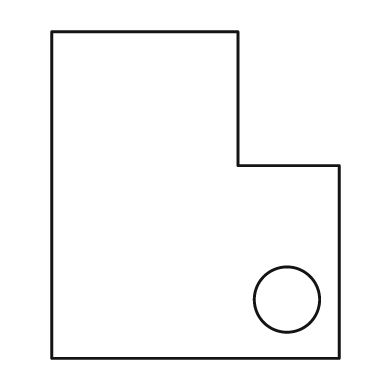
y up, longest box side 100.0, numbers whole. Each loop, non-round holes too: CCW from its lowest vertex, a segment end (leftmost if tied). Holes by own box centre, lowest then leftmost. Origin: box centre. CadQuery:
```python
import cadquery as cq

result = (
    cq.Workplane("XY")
    .moveTo(-44.0, -50.0)
    .lineTo(44.0, -50.0)
    .lineTo(44.0, 9.0)
    .lineTo(13.0, 9.0)
    .lineTo(13.0, 50.0)
    .lineTo(-44.0, 50.0)
    .close()
    .moveTo(28.0, -32.0)
    .circle(10.0)
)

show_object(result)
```